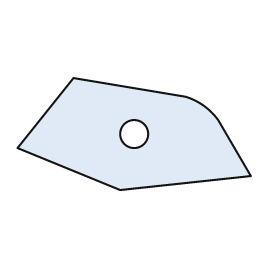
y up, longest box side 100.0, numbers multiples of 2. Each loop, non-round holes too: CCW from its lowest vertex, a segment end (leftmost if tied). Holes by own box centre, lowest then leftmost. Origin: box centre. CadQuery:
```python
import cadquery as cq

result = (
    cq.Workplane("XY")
    .moveTo(-6.0, -24.0)
    .lineTo(50.0, -18.0)
    .lineTo(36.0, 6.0)
    .threePointArc((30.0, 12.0), (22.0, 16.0))
    .lineTo(-26.0, 24.0)
    .lineTo(-50.0, -6.0)
    .close()
    .moveTo(0.0, 0.0)
    .circle(6.0)
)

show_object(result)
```